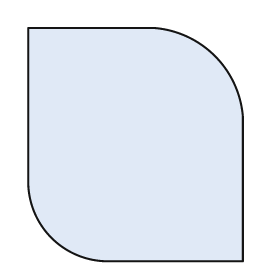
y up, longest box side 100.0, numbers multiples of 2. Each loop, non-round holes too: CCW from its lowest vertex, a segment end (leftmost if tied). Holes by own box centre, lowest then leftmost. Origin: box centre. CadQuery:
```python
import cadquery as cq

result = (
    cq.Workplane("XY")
    .moveTo(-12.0, -50.0)
    .lineTo(46.0, -50.0)
    .lineTo(46.0, 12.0)
    .threePointArc((34.0, 38.0), (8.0, 50.0))
    .lineTo(-46.0, 50.0)
    .lineTo(-46.0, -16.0)
    .threePointArc((-36.0, -40.0), (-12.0, -50.0))
    .close()
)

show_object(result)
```